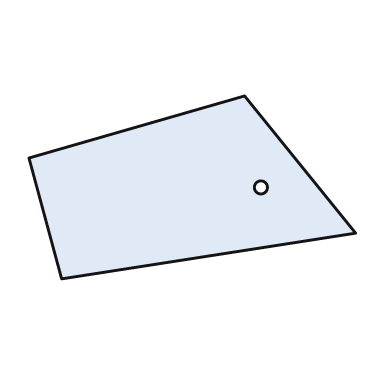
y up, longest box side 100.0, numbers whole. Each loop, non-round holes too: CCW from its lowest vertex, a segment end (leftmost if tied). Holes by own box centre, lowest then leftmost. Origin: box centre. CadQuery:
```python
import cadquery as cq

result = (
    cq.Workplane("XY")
    .moveTo(-40.0, -28.0)
    .lineTo(50.0, -14.0)
    .lineTo(16.0, 28.0)
    .lineTo(-50.0, 9.0)
    .close()
    .moveTo(21.0, 0.0)
    .circle(2.0)
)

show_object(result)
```